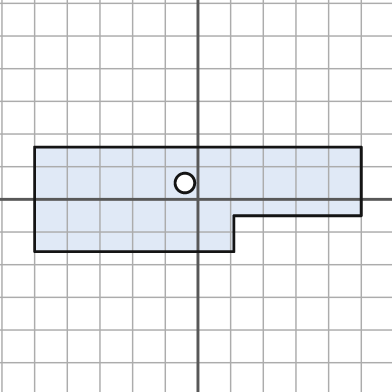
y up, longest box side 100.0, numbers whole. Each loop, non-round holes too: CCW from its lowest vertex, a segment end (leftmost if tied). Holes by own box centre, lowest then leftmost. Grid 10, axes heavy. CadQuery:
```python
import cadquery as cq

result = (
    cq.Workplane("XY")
    .moveTo(-50.0, -16.0)
    .lineTo(11.0, -16.0)
    .lineTo(11.0, -5.0)
    .lineTo(50.0, -5.0)
    .lineTo(50.0, 16.0)
    .lineTo(-50.0, 16.0)
    .close()
    .moveTo(-4.0, 5.0)
    .circle(3.0)
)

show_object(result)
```